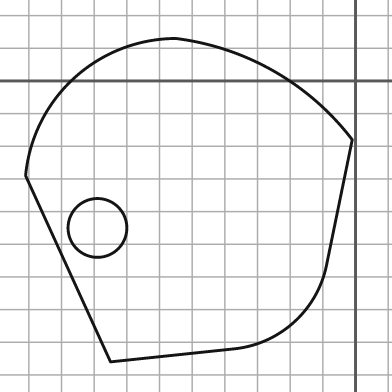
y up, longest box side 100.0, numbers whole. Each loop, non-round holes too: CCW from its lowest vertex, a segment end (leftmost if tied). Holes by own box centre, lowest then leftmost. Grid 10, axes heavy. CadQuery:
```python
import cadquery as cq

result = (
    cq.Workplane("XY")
    .moveTo(-75.0, -86.0)
    .lineTo(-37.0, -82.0)
    .threePointArc((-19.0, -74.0), (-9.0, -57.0))
    .lineTo(-1.0, -18.0)
    .threePointArc((-25.0, 3.0), (-55.0, 13.0))
    .threePointArc((-86.0, 1.0), (-101.0, -29.0))
    .close()
    .moveTo(-79.0, -45.0)
    .circle(9.0)
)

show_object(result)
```